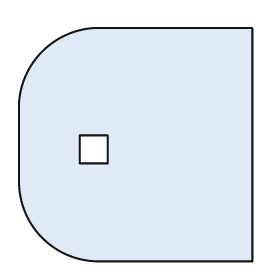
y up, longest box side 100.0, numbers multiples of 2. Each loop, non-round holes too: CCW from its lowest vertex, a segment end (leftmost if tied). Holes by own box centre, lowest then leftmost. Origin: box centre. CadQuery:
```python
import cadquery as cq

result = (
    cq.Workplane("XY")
    .moveTo(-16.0, -50.0)
    .lineTo(50.0, -50.0)
    .lineTo(50.0, 50.0)
    .lineTo(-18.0, 50.0)
    .threePointArc((-40.0, 40.0), (-50.0, 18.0))
    .lineTo(-50.0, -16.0)
    .threePointArc((-40.0, -40.0), (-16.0, -50.0))
    .close()
    .moveTo(-24.0, -8.0)
    .lineTo(-12.0, -8.0)
    .lineTo(-12.0, 4.0)
    .lineTo(-24.0, 4.0)
    .close()
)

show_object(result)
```